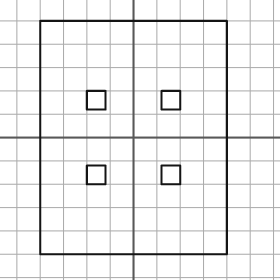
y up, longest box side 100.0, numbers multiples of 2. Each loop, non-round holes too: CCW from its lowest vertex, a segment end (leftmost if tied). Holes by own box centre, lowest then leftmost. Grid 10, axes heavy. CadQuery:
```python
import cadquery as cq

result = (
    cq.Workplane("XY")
    .moveTo(-40.0, -50.0)
    .lineTo(40.0, -50.0)
    .lineTo(40.0, 50.0)
    .lineTo(-40.0, 50.0)
    .close()
    .moveTo(-20.0, -20.0)
    .lineTo(-12.0, -20.0)
    .lineTo(-12.0, -12.0)
    .lineTo(-20.0, -12.0)
    .close()
    .moveTo(12.0, -20.0)
    .lineTo(20.0, -20.0)
    .lineTo(20.0, -12.0)
    .lineTo(12.0, -12.0)
    .close()
    .moveTo(-20.0, 12.0)
    .lineTo(-12.0, 12.0)
    .lineTo(-12.0, 20.0)
    .lineTo(-20.0, 20.0)
    .close()
    .moveTo(12.0, 12.0)
    .lineTo(20.0, 12.0)
    .lineTo(20.0, 20.0)
    .lineTo(12.0, 20.0)
    .close()
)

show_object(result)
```